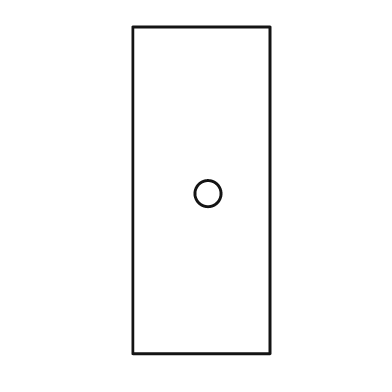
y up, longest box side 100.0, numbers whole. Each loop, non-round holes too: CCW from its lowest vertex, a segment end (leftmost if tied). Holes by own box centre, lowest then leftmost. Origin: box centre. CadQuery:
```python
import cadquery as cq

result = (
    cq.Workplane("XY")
    .moveTo(-21.0, -50.0)
    .lineTo(21.0, -50.0)
    .lineTo(21.0, 50.0)
    .lineTo(-21.0, 50.0)
    .close()
    .moveTo(2.0, -1.0)
    .circle(4.0)
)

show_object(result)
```